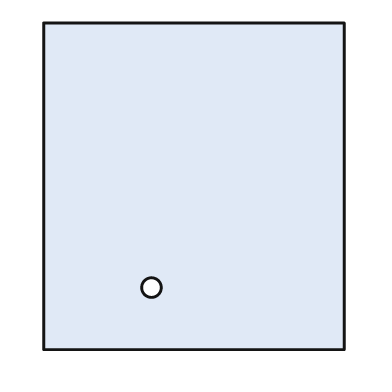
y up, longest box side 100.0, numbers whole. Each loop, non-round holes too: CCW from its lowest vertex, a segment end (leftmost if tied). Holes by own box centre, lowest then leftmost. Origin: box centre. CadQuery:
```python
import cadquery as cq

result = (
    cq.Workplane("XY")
    .moveTo(-46.0, -50.0)
    .lineTo(46.0, -50.0)
    .lineTo(46.0, 50.0)
    .lineTo(-46.0, 50.0)
    .close()
    .moveTo(-13.0, -31.0)
    .circle(3.0)
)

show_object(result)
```